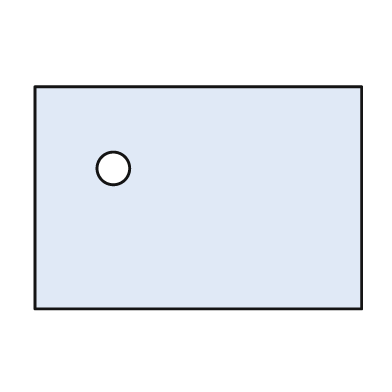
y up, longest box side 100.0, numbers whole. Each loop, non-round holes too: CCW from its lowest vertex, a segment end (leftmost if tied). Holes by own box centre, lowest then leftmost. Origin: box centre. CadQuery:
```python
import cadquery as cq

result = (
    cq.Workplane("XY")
    .moveTo(-50.0, -34.0)
    .lineTo(50.0, -34.0)
    .lineTo(50.0, 34.0)
    .lineTo(-50.0, 34.0)
    .close()
    .moveTo(-26.0, 9.0)
    .circle(5.0)
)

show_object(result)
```